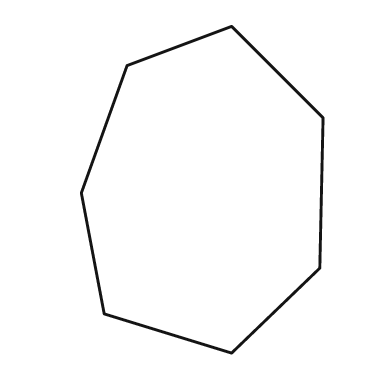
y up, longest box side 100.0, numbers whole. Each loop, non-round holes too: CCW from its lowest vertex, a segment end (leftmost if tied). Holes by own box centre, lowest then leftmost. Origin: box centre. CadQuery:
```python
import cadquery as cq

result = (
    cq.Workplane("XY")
    .moveTo(9.0, -50.0)
    .lineTo(36.0, -24.0)
    .lineTo(37.0, 22.0)
    .lineTo(9.0, 50.0)
    .lineTo(-23.0, 38.0)
    .lineTo(-37.0, -1.0)
    .lineTo(-30.0, -38.0)
    .close()
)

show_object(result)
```